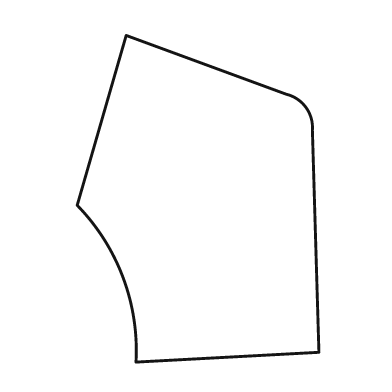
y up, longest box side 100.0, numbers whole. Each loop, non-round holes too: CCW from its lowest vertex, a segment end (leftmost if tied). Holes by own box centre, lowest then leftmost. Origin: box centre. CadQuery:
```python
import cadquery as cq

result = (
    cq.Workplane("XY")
    .moveTo(-19.0, -50.0)
    .lineTo(37.0, -47.0)
    .lineTo(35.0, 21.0)
    .threePointArc((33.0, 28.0), (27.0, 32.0))
    .lineTo(-22.0, 50.0)
    .lineTo(-37.0, -2.0)
    .threePointArc((-23.0, -24.0), (-19.0, -50.0))
    .close()
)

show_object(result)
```